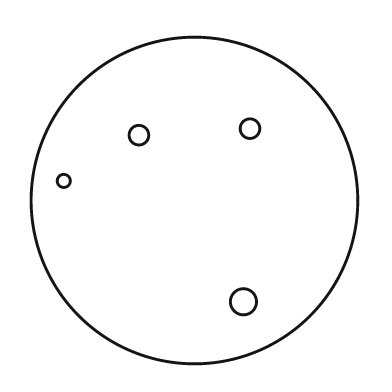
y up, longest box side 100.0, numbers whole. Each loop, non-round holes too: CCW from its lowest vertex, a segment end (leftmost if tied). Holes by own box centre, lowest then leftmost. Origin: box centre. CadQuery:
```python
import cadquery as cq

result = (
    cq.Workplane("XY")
    .moveTo(0.0, 0.0)
    .circle(50.0)
    .moveTo(15.0, -31.0)
    .circle(4.0)
    .moveTo(-40.0, 6.0)
    .circle(2.0)
    .moveTo(-17.0, 20.0)
    .circle(3.0)
    .moveTo(17.0, 22.0)
    .circle(3.0)
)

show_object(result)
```